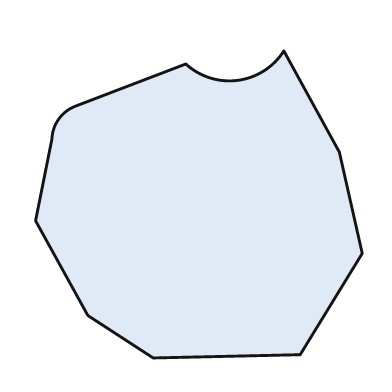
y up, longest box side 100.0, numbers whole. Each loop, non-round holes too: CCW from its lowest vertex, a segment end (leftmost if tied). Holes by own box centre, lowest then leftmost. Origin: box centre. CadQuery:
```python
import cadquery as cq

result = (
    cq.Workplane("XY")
    .moveTo(-14.0, -47.0)
    .lineTo(31.0, -46.0)
    .lineTo(50.0, -15.0)
    .lineTo(43.0, 16.0)
    .lineTo(26.0, 47.0)
    .threePointArc((12.0, 38.0), (-4.0, 43.0))
    .lineTo(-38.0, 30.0)
    .threePointArc((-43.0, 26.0), (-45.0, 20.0))
    .lineTo(-50.0, -5.0)
    .lineTo(-34.0, -34.0)
    .close()
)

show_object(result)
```